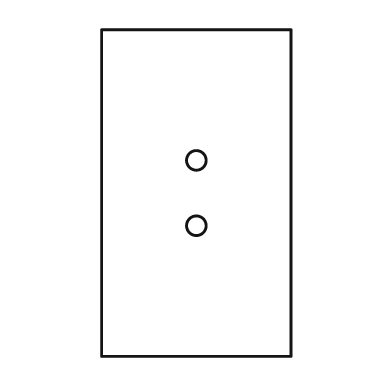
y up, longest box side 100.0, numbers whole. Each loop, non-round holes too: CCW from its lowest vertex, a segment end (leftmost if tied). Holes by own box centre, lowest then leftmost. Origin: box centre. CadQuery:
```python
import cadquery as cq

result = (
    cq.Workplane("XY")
    .moveTo(-29.0, -50.0)
    .lineTo(29.0, -50.0)
    .lineTo(29.0, 50.0)
    .lineTo(-29.0, 50.0)
    .close()
    .moveTo(0.0, -10.0)
    .circle(3.0)
    .moveTo(0.0, 10.0)
    .circle(3.0)
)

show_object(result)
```